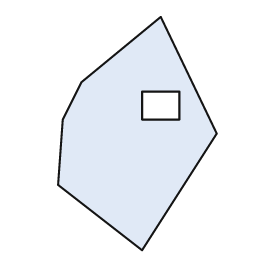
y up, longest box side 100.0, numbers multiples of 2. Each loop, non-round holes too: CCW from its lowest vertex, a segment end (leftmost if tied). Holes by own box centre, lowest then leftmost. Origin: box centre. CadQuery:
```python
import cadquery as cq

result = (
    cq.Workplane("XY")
    .moveTo(2.0, -50.0)
    .lineTo(34.0, 0.0)
    .lineTo(10.0, 50.0)
    .lineTo(-24.0, 22.0)
    .lineTo(-32.0, 6.0)
    .lineTo(-34.0, -22.0)
    .close()
    .moveTo(2.0, 6.0)
    .lineTo(18.0, 6.0)
    .lineTo(18.0, 18.0)
    .lineTo(2.0, 18.0)
    .close()
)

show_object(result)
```